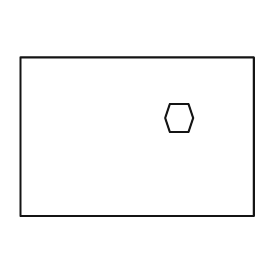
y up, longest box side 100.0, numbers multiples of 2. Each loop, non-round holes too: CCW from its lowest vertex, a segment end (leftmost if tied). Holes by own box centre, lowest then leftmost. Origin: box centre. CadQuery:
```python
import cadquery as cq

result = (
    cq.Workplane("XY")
    .moveTo(-50.0, -34.0)
    .lineTo(50.0, -34.0)
    .lineTo(50.0, 34.0)
    .lineTo(-50.0, 34.0)
    .close()
    .moveTo(14.0, 2.0)
    .lineTo(22.0, 2.0)
    .lineTo(24.0, 8.0)
    .lineTo(22.0, 14.0)
    .lineTo(14.0, 14.0)
    .lineTo(12.0, 8.0)
    .close()
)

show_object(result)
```